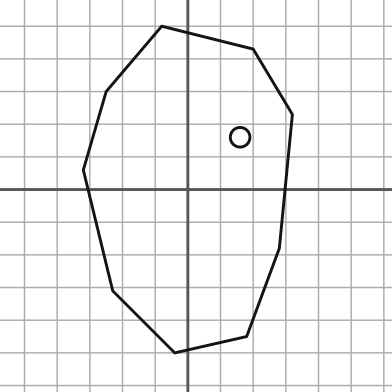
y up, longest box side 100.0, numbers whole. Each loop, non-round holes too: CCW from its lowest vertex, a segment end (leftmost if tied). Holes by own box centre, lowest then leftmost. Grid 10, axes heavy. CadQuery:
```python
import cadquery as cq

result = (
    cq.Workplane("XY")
    .moveTo(-4.0, -50.0)
    .lineTo(18.0, -45.0)
    .lineTo(28.0, -18.0)
    .lineTo(32.0, 23.0)
    .lineTo(20.0, 43.0)
    .lineTo(-8.0, 50.0)
    .lineTo(-25.0, 30.0)
    .lineTo(-32.0, 6.0)
    .lineTo(-23.0, -31.0)
    .close()
    .moveTo(16.0, 16.0)
    .circle(3.0)
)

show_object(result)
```